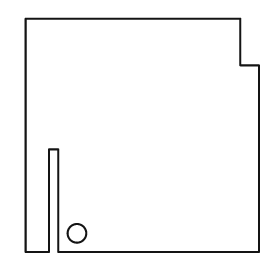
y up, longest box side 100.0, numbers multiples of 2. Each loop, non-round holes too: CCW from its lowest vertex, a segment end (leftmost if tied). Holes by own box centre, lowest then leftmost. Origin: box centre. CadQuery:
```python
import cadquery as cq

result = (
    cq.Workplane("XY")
    .moveTo(-50.0, -50.0)
    .lineTo(-40.0, -50.0)
    .lineTo(-40.0, -6.0)
    .lineTo(-36.0, -6.0)
    .lineTo(-36.0, -50.0)
    .lineTo(50.0, -50.0)
    .lineTo(50.0, 30.0)
    .lineTo(42.0, 30.0)
    .lineTo(42.0, 50.0)
    .lineTo(-50.0, 50.0)
    .close()
    .moveTo(-28.0, -42.0)
    .circle(4.0)
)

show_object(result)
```